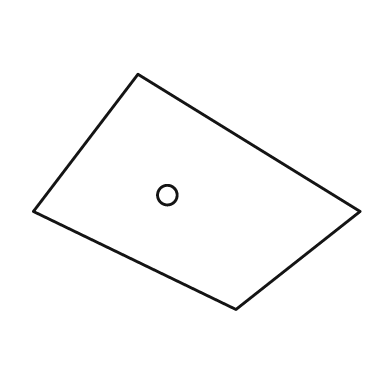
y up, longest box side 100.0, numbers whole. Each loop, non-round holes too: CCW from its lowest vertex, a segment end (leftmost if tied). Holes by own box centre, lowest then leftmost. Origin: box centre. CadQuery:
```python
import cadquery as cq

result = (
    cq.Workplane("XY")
    .moveTo(12.0, -36.0)
    .lineTo(50.0, -6.0)
    .lineTo(-18.0, 36.0)
    .lineTo(-50.0, -6.0)
    .close()
    .moveTo(-9.0, -1.0)
    .circle(3.0)
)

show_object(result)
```